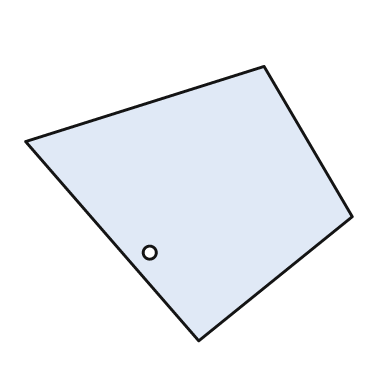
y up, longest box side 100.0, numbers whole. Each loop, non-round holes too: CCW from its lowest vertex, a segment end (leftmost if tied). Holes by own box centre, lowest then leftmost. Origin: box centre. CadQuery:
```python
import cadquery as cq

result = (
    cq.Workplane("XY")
    .moveTo(3.0, -42.0)
    .lineTo(50.0, -4.0)
    .lineTo(23.0, 42.0)
    .lineTo(-50.0, 19.0)
    .close()
    .moveTo(-12.0, -15.0)
    .circle(2.0)
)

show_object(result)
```